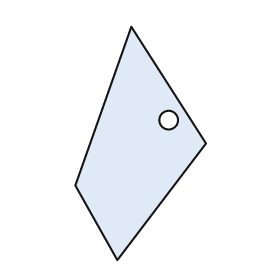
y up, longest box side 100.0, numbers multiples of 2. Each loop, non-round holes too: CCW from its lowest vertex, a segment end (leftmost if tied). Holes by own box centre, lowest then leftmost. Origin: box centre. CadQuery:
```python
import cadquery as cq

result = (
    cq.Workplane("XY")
    .moveTo(-10.0, -50.0)
    .lineTo(28.0, 0.0)
    .lineTo(-4.0, 50.0)
    .lineTo(-28.0, -18.0)
    .close()
    .moveTo(12.0, 10.0)
    .circle(4.0)
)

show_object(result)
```